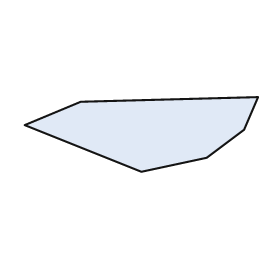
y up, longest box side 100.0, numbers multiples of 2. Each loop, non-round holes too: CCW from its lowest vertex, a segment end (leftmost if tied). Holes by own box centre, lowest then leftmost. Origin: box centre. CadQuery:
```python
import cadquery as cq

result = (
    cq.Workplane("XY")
    .moveTo(0.0, -16.0)
    .lineTo(28.0, -10.0)
    .lineTo(44.0, 2.0)
    .lineTo(50.0, 16.0)
    .lineTo(-26.0, 14.0)
    .lineTo(-50.0, 4.0)
    .close()
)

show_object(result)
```